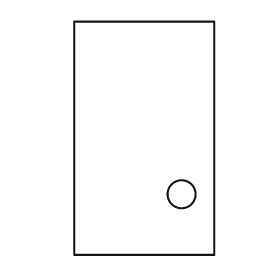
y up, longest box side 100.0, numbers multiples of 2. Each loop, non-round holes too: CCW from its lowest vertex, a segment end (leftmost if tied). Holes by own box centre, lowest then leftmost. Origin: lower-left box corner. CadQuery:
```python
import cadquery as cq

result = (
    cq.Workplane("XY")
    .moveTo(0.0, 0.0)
    .lineTo(60.0, 0.0)
    .lineTo(60.0, 100.0)
    .lineTo(0.0, 100.0)
    .close()
    .moveTo(46.0, 26.0)
    .circle(6.0)
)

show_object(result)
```